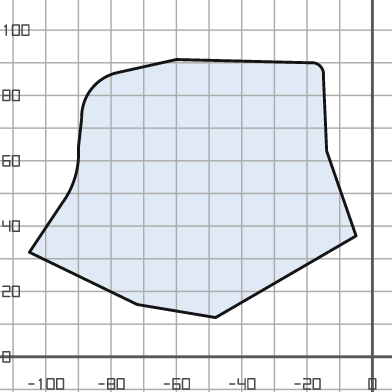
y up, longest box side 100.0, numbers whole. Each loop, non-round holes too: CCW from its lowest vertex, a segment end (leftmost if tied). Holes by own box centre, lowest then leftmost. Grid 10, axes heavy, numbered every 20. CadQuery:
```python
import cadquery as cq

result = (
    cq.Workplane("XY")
    .moveTo(-48.0, 12.0)
    .lineTo(-5.0, 37.0)
    .lineTo(-14.0, 63.0)
    .lineTo(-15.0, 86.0)
    .threePointArc((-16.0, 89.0), (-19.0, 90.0))
    .lineTo(-60.0, 91.0)
    .lineTo(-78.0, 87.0)
    .threePointArc((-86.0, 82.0), (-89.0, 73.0))
    .lineTo(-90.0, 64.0)
    .threePointArc((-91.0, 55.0), (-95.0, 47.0))
    .lineTo(-105.0, 32.0)
    .lineTo(-72.0, 16.0)
    .close()
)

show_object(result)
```